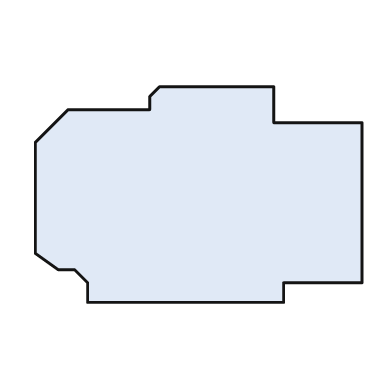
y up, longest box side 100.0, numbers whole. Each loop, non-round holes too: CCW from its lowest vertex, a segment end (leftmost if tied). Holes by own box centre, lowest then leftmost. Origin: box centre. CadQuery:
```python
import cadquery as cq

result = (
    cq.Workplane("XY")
    .moveTo(-34.0, -33.0)
    .lineTo(26.0, -33.0)
    .lineTo(26.0, -27.0)
    .lineTo(50.0, -27.0)
    .lineTo(50.0, 22.0)
    .lineTo(23.0, 22.0)
    .lineTo(23.0, 33.0)
    .lineTo(-12.0, 33.0)
    .lineTo(-15.0, 30.0)
    .lineTo(-15.0, 26.0)
    .lineTo(-40.0, 26.0)
    .lineTo(-50.0, 16.0)
    .lineTo(-50.0, -18.0)
    .lineTo(-43.0, -23.0)
    .lineTo(-38.0, -23.0)
    .lineTo(-34.0, -27.0)
    .close()
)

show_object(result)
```